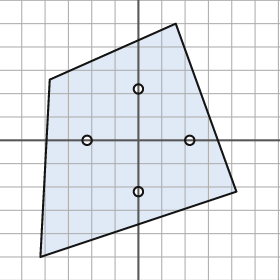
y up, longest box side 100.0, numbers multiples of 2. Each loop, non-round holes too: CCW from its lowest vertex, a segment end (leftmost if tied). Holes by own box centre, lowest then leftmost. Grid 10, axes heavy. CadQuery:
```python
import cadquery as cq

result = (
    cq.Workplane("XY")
    .moveTo(-42.0, -50.0)
    .lineTo(42.0, -22.0)
    .lineTo(16.0, 50.0)
    .lineTo(-38.0, 26.0)
    .close()
    .moveTo(0.0, -22.0)
    .circle(2.0)
    .moveTo(-22.0, 0.0)
    .circle(2.0)
    .moveTo(22.0, 0.0)
    .circle(2.0)
    .moveTo(0.0, 22.0)
    .circle(2.0)
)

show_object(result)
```